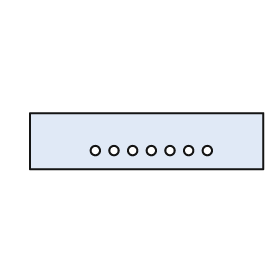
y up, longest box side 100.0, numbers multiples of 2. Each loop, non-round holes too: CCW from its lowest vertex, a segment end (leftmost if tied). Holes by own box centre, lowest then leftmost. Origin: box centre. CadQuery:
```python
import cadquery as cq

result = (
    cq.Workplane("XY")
    .moveTo(-50.0, -12.0)
    .lineTo(50.0, -12.0)
    .lineTo(50.0, 12.0)
    .lineTo(-50.0, 12.0)
    .close()
    .moveTo(-22.0, -4.0)
    .circle(2.0)
    .moveTo(-14.0, -4.0)
    .circle(2.0)
    .moveTo(-6.0, -4.0)
    .circle(2.0)
    .moveTo(2.0, -4.0)
    .circle(2.0)
    .moveTo(10.0, -4.0)
    .circle(2.0)
    .moveTo(18.0, -4.0)
    .circle(2.0)
    .moveTo(26.0, -4.0)
    .circle(2.0)
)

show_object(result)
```